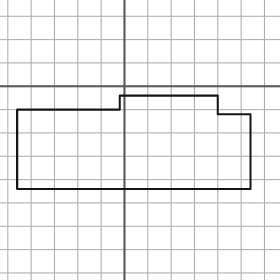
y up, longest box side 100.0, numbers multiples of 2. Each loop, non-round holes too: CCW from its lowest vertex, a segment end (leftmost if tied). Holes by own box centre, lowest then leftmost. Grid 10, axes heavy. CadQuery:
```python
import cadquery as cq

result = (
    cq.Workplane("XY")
    .moveTo(-46.0, -44.0)
    .lineTo(54.0, -44.0)
    .lineTo(54.0, -12.0)
    .lineTo(40.0, -12.0)
    .lineTo(40.0, -4.0)
    .lineTo(-2.0, -4.0)
    .lineTo(-2.0, -10.0)
    .lineTo(-46.0, -10.0)
    .close()
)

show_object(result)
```